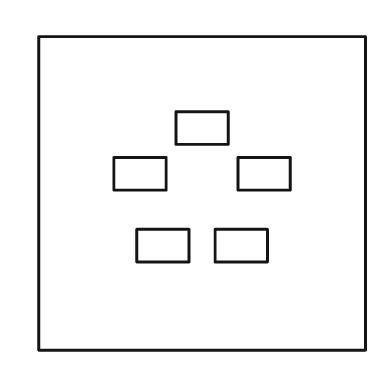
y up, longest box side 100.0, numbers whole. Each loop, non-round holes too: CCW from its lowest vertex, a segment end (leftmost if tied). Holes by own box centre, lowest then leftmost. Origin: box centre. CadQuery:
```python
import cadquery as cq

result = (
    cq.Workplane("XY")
    .moveTo(-50.0, -48.0)
    .lineTo(50.0, -48.0)
    .lineTo(50.0, 48.0)
    .lineTo(-50.0, 48.0)
    .close()
    .moveTo(-20.0, -21.0)
    .lineTo(-4.0, -21.0)
    .lineTo(-4.0, -11.0)
    .lineTo(-20.0, -11.0)
    .close()
    .moveTo(4.0, -21.0)
    .lineTo(20.0, -21.0)
    .lineTo(20.0, -11.0)
    .lineTo(4.0, -11.0)
    .close()
    .moveTo(-27.0, 1.0)
    .lineTo(-11.0, 1.0)
    .lineTo(-11.0, 11.0)
    .lineTo(-27.0, 11.0)
    .close()
    .moveTo(11.0, 1.0)
    .lineTo(27.0, 1.0)
    .lineTo(27.0, 11.0)
    .lineTo(11.0, 11.0)
    .close()
    .moveTo(-8.0, 15.0)
    .lineTo(8.0, 15.0)
    .lineTo(8.0, 25.0)
    .lineTo(-8.0, 25.0)
    .close()
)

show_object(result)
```